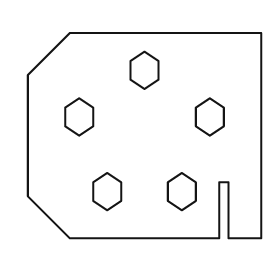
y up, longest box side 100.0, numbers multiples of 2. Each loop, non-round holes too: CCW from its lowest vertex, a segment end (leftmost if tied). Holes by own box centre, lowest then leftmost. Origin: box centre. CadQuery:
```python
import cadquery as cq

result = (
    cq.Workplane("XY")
    .moveTo(-32.0, -44.0)
    .lineTo(32.0, -44.0)
    .lineTo(32.0, -20.0)
    .lineTo(36.0, -20.0)
    .lineTo(36.0, -44.0)
    .lineTo(50.0, -44.0)
    .lineTo(50.0, 44.0)
    .lineTo(-32.0, 44.0)
    .lineTo(-50.0, 26.0)
    .lineTo(-50.0, -26.0)
    .close()
    .moveTo(-16.0, -32.0)
    .lineTo(-10.0, -28.0)
    .lineTo(-10.0, -20.0)
    .lineTo(-16.0, -16.0)
    .lineTo(-22.0, -20.0)
    .lineTo(-22.0, -28.0)
    .close()
    .moveTo(16.0, -32.0)
    .lineTo(22.0, -28.0)
    .lineTo(22.0, -20.0)
    .lineTo(16.0, -16.0)
    .lineTo(10.0, -20.0)
    .lineTo(10.0, -28.0)
    .close()
    .moveTo(-28.0, 0.0)
    .lineTo(-22.0, 4.0)
    .lineTo(-22.0, 12.0)
    .lineTo(-28.0, 16.0)
    .lineTo(-34.0, 12.0)
    .lineTo(-34.0, 4.0)
    .close()
    .moveTo(28.0, 0.0)
    .lineTo(34.0, 4.0)
    .lineTo(34.0, 12.0)
    .lineTo(28.0, 16.0)
    .lineTo(22.0, 12.0)
    .lineTo(22.0, 4.0)
    .close()
    .moveTo(0.0, 20.0)
    .lineTo(6.0, 24.0)
    .lineTo(6.0, 32.0)
    .lineTo(0.0, 36.0)
    .lineTo(-6.0, 32.0)
    .lineTo(-6.0, 24.0)
    .close()
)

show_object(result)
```